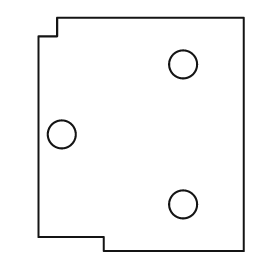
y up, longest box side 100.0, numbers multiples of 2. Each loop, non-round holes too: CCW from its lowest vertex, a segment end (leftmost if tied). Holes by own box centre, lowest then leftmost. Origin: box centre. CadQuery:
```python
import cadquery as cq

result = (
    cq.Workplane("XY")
    .moveTo(-16.0, -50.0)
    .lineTo(44.0, -50.0)
    .lineTo(44.0, 50.0)
    .lineTo(-36.0, 50.0)
    .lineTo(-36.0, 42.0)
    .lineTo(-44.0, 42.0)
    .lineTo(-44.0, -44.0)
    .lineTo(-16.0, -44.0)
    .close()
    .moveTo(18.0, -30.0)
    .circle(6.0)
    .moveTo(-34.0, 0.0)
    .circle(6.0)
    .moveTo(18.0, 30.0)
    .circle(6.0)
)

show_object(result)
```